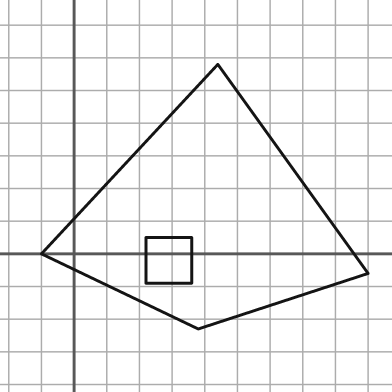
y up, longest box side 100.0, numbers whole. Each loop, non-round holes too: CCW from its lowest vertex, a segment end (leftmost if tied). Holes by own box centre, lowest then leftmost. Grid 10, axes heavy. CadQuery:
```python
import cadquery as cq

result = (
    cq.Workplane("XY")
    .moveTo(38.0, -23.0)
    .lineTo(90.0, -6.0)
    .lineTo(44.0, 58.0)
    .lineTo(-10.0, 0.0)
    .close()
    .moveTo(22.0, -9.0)
    .lineTo(36.0, -9.0)
    .lineTo(36.0, 5.0)
    .lineTo(22.0, 5.0)
    .close()
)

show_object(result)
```